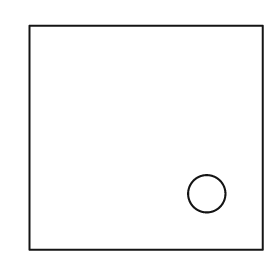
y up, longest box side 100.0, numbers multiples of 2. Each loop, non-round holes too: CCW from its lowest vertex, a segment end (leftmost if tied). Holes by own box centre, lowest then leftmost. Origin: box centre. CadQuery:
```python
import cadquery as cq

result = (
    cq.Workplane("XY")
    .moveTo(-50.0, -48.0)
    .lineTo(50.0, -48.0)
    .lineTo(50.0, 48.0)
    .lineTo(-50.0, 48.0)
    .close()
    .moveTo(26.0, -24.0)
    .circle(8.0)
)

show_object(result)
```